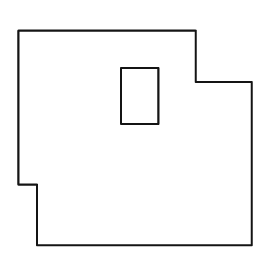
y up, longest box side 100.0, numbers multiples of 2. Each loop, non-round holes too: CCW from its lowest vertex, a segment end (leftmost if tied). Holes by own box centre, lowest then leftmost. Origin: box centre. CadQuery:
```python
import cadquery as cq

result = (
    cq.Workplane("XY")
    .moveTo(-42.0, -46.0)
    .lineTo(50.0, -46.0)
    .lineTo(50.0, 24.0)
    .lineTo(26.0, 24.0)
    .lineTo(26.0, 46.0)
    .lineTo(-50.0, 46.0)
    .lineTo(-50.0, -20.0)
    .lineTo(-42.0, -20.0)
    .close()
    .moveTo(-6.0, 6.0)
    .lineTo(10.0, 6.0)
    .lineTo(10.0, 30.0)
    .lineTo(-6.0, 30.0)
    .close()
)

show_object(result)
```